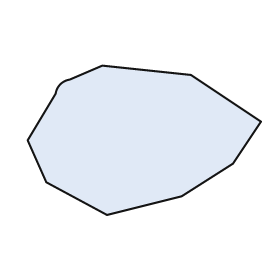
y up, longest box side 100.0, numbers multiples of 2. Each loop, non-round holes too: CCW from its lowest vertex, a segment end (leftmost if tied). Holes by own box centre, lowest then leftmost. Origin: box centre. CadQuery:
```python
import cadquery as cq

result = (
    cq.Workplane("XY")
    .moveTo(-16.0, -32.0)
    .lineTo(16.0, -24.0)
    .lineTo(38.0, -10.0)
    .lineTo(50.0, 8.0)
    .lineTo(20.0, 28.0)
    .lineTo(-18.0, 32.0)
    .lineTo(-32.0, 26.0)
    .threePointArc((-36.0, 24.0), (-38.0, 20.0))
    .lineTo(-50.0, 0.0)
    .lineTo(-42.0, -18.0)
    .close()
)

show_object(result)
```